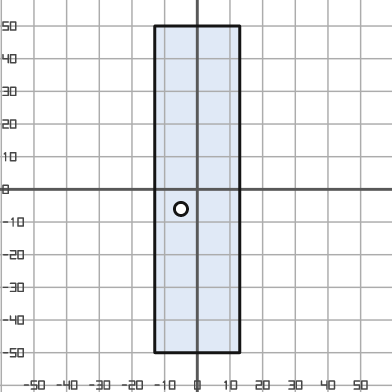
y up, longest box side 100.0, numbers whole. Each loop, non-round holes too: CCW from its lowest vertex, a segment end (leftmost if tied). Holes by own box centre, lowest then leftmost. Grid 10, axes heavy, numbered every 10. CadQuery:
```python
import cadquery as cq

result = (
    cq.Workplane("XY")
    .moveTo(-13.0, -50.0)
    .lineTo(13.0, -50.0)
    .lineTo(13.0, 50.0)
    .lineTo(-13.0, 50.0)
    .close()
    .moveTo(-5.0, -6.0)
    .circle(2.0)
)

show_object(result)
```